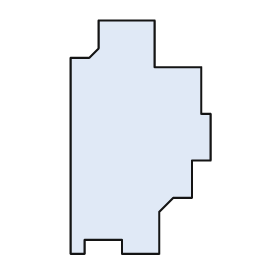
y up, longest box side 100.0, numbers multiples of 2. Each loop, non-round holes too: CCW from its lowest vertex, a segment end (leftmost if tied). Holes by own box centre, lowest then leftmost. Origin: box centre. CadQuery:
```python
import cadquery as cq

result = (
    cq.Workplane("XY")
    .moveTo(-30.0, -50.0)
    .lineTo(-24.0, -50.0)
    .lineTo(-24.0, -44.0)
    .lineTo(-8.0, -44.0)
    .lineTo(-8.0, -50.0)
    .lineTo(8.0, -50.0)
    .lineTo(8.0, -32.0)
    .lineTo(14.0, -26.0)
    .lineTo(22.0, -26.0)
    .lineTo(22.0, -10.0)
    .lineTo(30.0, -10.0)
    .lineTo(30.0, 10.0)
    .lineTo(26.0, 10.0)
    .lineTo(26.0, 30.0)
    .lineTo(6.0, 30.0)
    .lineTo(6.0, 50.0)
    .lineTo(-18.0, 50.0)
    .lineTo(-18.0, 38.0)
    .lineTo(-22.0, 34.0)
    .lineTo(-30.0, 34.0)
    .close()
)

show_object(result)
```